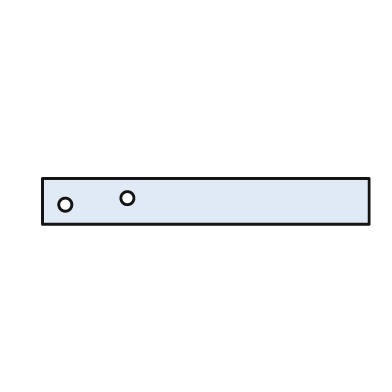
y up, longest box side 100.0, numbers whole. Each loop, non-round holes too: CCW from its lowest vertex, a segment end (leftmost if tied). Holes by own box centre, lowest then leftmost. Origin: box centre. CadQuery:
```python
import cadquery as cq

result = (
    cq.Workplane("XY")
    .moveTo(-50.0, -7.0)
    .lineTo(50.0, -7.0)
    .lineTo(50.0, 7.0)
    .lineTo(-50.0, 7.0)
    .close()
    .moveTo(-43.0, -1.0)
    .circle(2.0)
    .moveTo(-24.0, 1.0)
    .circle(2.0)
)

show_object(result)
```